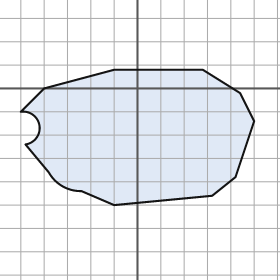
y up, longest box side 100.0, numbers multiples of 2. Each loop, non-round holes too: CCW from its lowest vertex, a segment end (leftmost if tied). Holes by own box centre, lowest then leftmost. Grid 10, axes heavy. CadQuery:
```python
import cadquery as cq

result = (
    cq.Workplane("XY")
    .moveTo(-10.0, -50.0)
    .lineTo(32.0, -46.0)
    .lineTo(42.0, -38.0)
    .lineTo(50.0, -14.0)
    .lineTo(44.0, -2.0)
    .lineTo(28.0, 8.0)
    .lineTo(-10.0, 8.0)
    .lineTo(-40.0, 0.0)
    .lineTo(-50.0, -10.0)
    .threePointArc((-42.0, -16.0), (-48.0, -24.0))
    .lineTo(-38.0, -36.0)
    .threePointArc((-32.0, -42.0), (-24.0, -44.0))
    .close()
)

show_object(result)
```